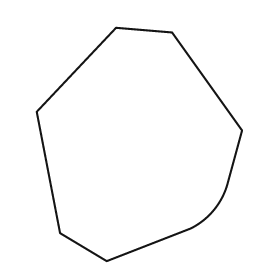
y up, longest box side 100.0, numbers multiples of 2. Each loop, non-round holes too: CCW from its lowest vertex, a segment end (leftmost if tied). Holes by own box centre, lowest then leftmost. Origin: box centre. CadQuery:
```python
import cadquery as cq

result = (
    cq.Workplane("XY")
    .moveTo(-14.0, -50.0)
    .lineTo(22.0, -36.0)
    .threePointArc((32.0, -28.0), (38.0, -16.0))
    .lineTo(44.0, 6.0)
    .lineTo(14.0, 48.0)
    .lineTo(-10.0, 50.0)
    .lineTo(-44.0, 14.0)
    .lineTo(-34.0, -38.0)
    .close()
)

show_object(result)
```